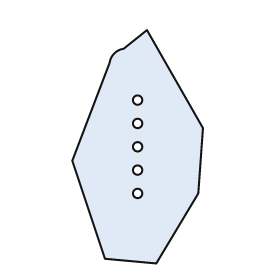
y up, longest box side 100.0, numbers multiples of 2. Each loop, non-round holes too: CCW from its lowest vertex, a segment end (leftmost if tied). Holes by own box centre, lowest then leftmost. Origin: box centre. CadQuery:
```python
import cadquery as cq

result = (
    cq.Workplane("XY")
    .moveTo(8.0, -50.0)
    .lineTo(26.0, -20.0)
    .lineTo(28.0, 8.0)
    .lineTo(4.0, 50.0)
    .lineTo(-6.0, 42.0)
    .threePointArc((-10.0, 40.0), (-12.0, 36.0))
    .lineTo(-28.0, -6.0)
    .lineTo(-14.0, -48.0)
    .close()
    .moveTo(0.0, -20.0)
    .circle(2.0)
    .moveTo(0.0, -10.0)
    .circle(2.0)
    .moveTo(0.0, 0.0)
    .circle(2.0)
    .moveTo(0.0, 10.0)
    .circle(2.0)
    .moveTo(0.0, 20.0)
    .circle(2.0)
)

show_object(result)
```